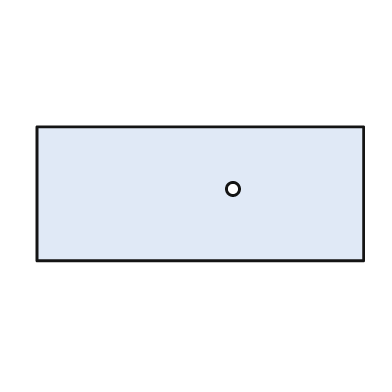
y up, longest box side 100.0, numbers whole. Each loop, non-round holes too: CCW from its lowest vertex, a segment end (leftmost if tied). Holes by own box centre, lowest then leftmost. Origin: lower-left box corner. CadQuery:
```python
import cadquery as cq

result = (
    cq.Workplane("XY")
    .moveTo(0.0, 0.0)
    .lineTo(100.0, 0.0)
    .lineTo(100.0, 41.0)
    .lineTo(0.0, 41.0)
    .close()
    .moveTo(60.0, 22.0)
    .circle(2.0)
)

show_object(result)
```